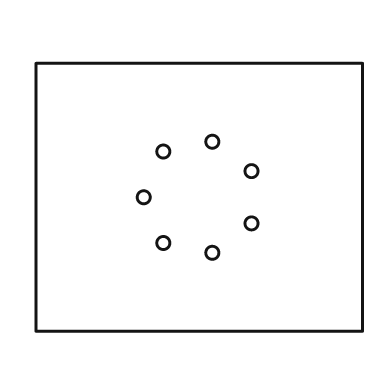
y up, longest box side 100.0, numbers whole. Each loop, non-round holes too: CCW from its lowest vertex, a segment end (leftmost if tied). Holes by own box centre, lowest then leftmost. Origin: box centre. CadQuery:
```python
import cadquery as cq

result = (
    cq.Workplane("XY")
    .moveTo(-50.0, -41.0)
    .lineTo(50.0, -41.0)
    .lineTo(50.0, 41.0)
    .lineTo(-50.0, 41.0)
    .close()
    .moveTo(4.0, -17.0)
    .circle(2.0)
    .moveTo(-11.0, -14.0)
    .circle(2.0)
    .moveTo(16.0, -8.0)
    .circle(2.0)
    .moveTo(-17.0, 0.0)
    .circle(2.0)
    .moveTo(16.0, 8.0)
    .circle(2.0)
    .moveTo(-11.0, 14.0)
    .circle(2.0)
    .moveTo(4.0, 17.0)
    .circle(2.0)
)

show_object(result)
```